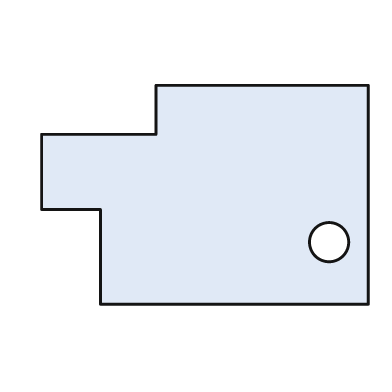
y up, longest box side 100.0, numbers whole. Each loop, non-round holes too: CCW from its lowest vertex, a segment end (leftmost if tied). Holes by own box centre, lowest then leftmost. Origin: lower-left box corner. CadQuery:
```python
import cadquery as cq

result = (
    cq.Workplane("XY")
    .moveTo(18.0, 0.0)
    .lineTo(100.0, 0.0)
    .lineTo(100.0, 67.0)
    .lineTo(35.0, 67.0)
    .lineTo(35.0, 52.0)
    .lineTo(0.0, 52.0)
    .lineTo(0.0, 29.0)
    .lineTo(18.0, 29.0)
    .close()
    .moveTo(88.0, 19.0)
    .circle(6.0)
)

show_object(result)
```